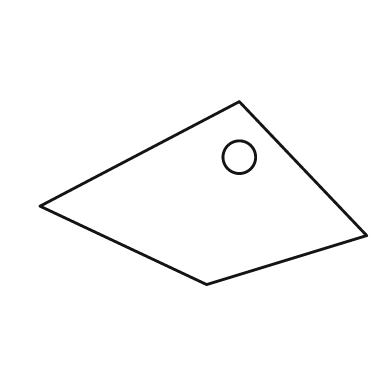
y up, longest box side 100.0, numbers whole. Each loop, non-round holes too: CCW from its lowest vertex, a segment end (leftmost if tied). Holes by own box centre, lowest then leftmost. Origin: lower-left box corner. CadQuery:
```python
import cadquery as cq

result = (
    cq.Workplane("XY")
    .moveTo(51.0, 0.0)
    .lineTo(100.0, 15.0)
    .lineTo(61.0, 56.0)
    .lineTo(0.0, 24.0)
    .close()
    .moveTo(61.0, 39.0)
    .circle(5.0)
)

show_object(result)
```